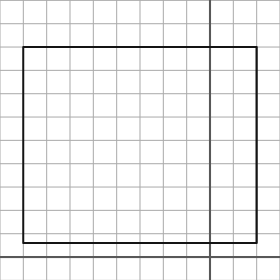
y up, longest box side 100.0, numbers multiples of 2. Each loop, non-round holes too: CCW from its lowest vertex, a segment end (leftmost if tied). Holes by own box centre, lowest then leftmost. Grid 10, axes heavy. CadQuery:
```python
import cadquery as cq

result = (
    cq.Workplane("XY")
    .moveTo(-80.0, 6.0)
    .lineTo(20.0, 6.0)
    .lineTo(20.0, 90.0)
    .lineTo(-80.0, 90.0)
    .close()
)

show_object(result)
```